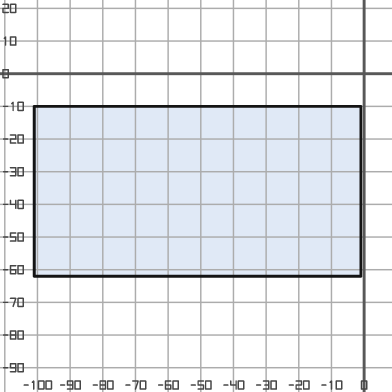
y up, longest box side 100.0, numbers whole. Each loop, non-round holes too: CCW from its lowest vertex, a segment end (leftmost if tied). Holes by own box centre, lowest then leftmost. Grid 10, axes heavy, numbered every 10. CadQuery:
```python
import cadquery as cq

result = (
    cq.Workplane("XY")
    .moveTo(-101.0, -62.0)
    .lineTo(-1.0, -62.0)
    .lineTo(-1.0, -10.0)
    .lineTo(-101.0, -10.0)
    .close()
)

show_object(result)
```